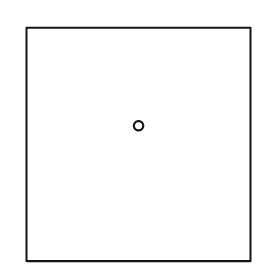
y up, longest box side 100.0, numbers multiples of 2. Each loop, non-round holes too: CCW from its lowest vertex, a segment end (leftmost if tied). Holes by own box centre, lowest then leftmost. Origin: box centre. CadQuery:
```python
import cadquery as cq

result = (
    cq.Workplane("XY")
    .moveTo(-48.0, -50.0)
    .lineTo(48.0, -50.0)
    .lineTo(48.0, 50.0)
    .lineTo(-48.0, 50.0)
    .close()
    .moveTo(0.0, 8.0)
    .circle(2.0)
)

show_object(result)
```